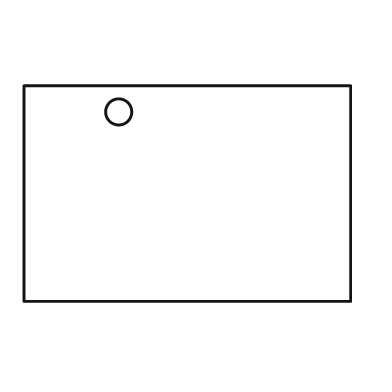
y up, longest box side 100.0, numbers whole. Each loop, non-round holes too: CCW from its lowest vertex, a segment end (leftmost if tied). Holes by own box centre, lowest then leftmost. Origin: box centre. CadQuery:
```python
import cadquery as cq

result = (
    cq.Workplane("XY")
    .moveTo(-50.0, -33.0)
    .lineTo(50.0, -33.0)
    .lineTo(50.0, 33.0)
    .lineTo(-50.0, 33.0)
    .close()
    .moveTo(-21.0, 25.0)
    .circle(4.0)
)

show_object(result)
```